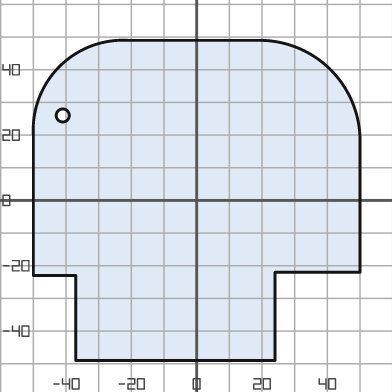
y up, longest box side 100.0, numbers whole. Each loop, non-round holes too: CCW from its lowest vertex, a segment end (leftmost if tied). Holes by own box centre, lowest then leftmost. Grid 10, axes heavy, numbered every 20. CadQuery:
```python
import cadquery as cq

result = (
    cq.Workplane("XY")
    .moveTo(-37.0, -49.0)
    .lineTo(24.0, -49.0)
    .lineTo(24.0, -22.0)
    .lineTo(50.0, -22.0)
    .lineTo(50.0, 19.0)
    .threePointArc((41.0, 40.0), (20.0, 49.0))
    .lineTo(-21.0, 49.0)
    .threePointArc((-42.0, 41.0), (-50.0, 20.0))
    .lineTo(-50.0, -23.0)
    .lineTo(-37.0, -23.0)
    .close()
    .moveTo(-41.0, 26.0)
    .circle(2.0)
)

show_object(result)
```